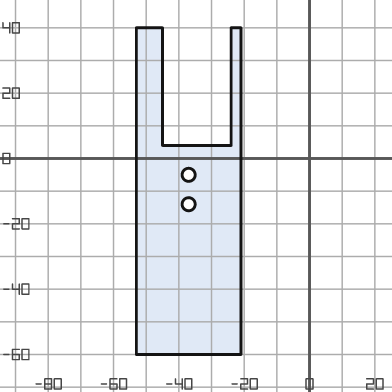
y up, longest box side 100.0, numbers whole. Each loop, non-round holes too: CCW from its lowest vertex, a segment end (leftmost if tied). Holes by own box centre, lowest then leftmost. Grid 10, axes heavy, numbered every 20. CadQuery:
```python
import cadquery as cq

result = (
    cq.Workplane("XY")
    .moveTo(-53.0, -60.0)
    .lineTo(-21.0, -60.0)
    .lineTo(-21.0, 40.0)
    .lineTo(-24.0, 40.0)
    .lineTo(-24.0, 4.0)
    .lineTo(-45.0, 4.0)
    .lineTo(-45.0, 40.0)
    .lineTo(-53.0, 40.0)
    .close()
    .moveTo(-37.0, -14.0)
    .circle(2.0)
    .moveTo(-37.0, -5.0)
    .circle(2.0)
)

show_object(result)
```